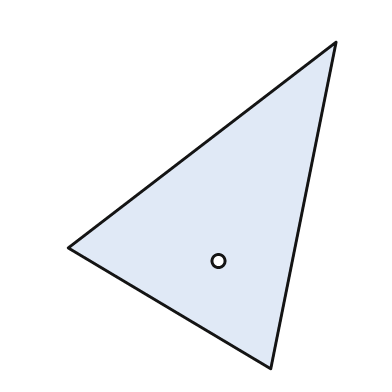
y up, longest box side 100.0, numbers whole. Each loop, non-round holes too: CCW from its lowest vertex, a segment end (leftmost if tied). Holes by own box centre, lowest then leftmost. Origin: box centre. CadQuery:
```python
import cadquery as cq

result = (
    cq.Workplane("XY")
    .moveTo(21.0, -50.0)
    .lineTo(41.0, 50.0)
    .lineTo(-41.0, -13.0)
    .close()
    .moveTo(5.0, -17.0)
    .circle(2.0)
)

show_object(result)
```